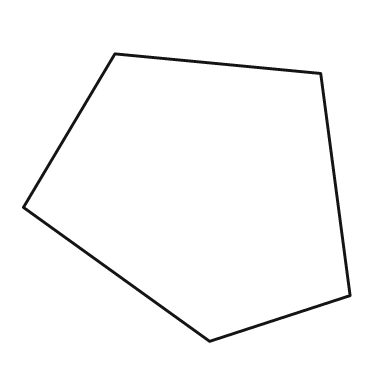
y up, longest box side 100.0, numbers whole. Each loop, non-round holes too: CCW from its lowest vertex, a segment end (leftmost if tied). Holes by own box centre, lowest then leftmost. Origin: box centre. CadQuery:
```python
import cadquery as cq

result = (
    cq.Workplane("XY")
    .moveTo(7.0, -44.0)
    .lineTo(50.0, -30.0)
    .lineTo(41.0, 38.0)
    .lineTo(-22.0, 44.0)
    .lineTo(-50.0, -3.0)
    .close()
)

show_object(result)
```